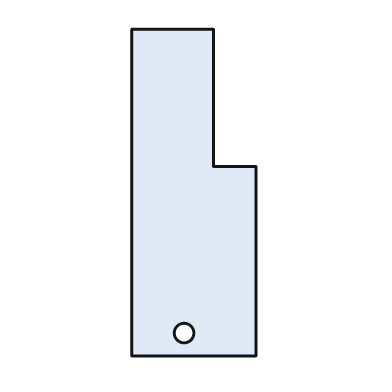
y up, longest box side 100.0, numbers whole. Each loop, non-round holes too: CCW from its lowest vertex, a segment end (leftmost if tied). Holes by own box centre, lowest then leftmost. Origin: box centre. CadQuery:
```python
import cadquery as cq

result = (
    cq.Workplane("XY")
    .moveTo(-19.0, -50.0)
    .lineTo(19.0, -50.0)
    .lineTo(19.0, 8.0)
    .lineTo(6.0, 8.0)
    .lineTo(6.0, 50.0)
    .lineTo(-19.0, 50.0)
    .close()
    .moveTo(-3.0, -43.0)
    .circle(3.0)
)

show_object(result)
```